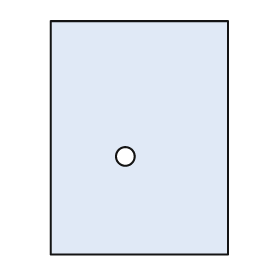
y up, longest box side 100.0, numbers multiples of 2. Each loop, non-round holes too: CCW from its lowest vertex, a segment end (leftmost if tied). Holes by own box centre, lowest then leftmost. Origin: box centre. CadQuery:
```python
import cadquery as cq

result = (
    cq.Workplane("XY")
    .moveTo(-38.0, -50.0)
    .lineTo(38.0, -50.0)
    .lineTo(38.0, 50.0)
    .lineTo(-38.0, 50.0)
    .close()
    .moveTo(-6.0, -8.0)
    .circle(4.0)
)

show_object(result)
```